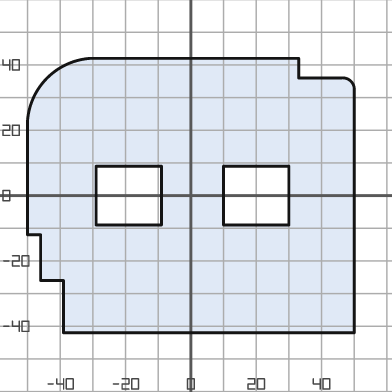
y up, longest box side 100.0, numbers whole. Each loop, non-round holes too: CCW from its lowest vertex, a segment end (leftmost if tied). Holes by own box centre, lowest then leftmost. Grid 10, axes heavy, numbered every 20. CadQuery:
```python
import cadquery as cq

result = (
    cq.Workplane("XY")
    .moveTo(-39.0, -42.0)
    .lineTo(50.0, -42.0)
    .lineTo(50.0, 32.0)
    .threePointArc((49.0, 35.0), (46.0, 36.0))
    .lineTo(33.0, 36.0)
    .lineTo(33.0, 42.0)
    .lineTo(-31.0, 42.0)
    .threePointArc((-44.0, 36.0), (-50.0, 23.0))
    .lineTo(-50.0, -12.0)
    .lineTo(-46.0, -12.0)
    .lineTo(-46.0, -26.0)
    .lineTo(-39.0, -26.0)
    .close()
    .moveTo(-29.0, -9.0)
    .lineTo(-9.0, -9.0)
    .lineTo(-9.0, 9.0)
    .lineTo(-29.0, 9.0)
    .close()
    .moveTo(10.0, -9.0)
    .lineTo(30.0, -9.0)
    .lineTo(30.0, 9.0)
    .lineTo(10.0, 9.0)
    .close()
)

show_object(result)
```